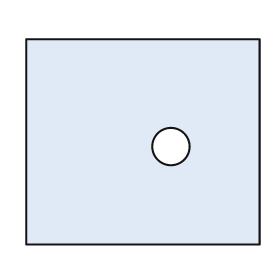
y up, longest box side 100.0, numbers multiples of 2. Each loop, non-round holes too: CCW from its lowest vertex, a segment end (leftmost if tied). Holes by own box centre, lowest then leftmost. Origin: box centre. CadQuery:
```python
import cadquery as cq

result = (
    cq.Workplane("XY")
    .moveTo(-50.0, -44.0)
    .lineTo(50.0, -44.0)
    .lineTo(50.0, 44.0)
    .lineTo(-50.0, 44.0)
    .close()
    .moveTo(12.0, -2.0)
    .circle(8.0)
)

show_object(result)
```